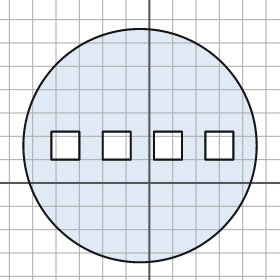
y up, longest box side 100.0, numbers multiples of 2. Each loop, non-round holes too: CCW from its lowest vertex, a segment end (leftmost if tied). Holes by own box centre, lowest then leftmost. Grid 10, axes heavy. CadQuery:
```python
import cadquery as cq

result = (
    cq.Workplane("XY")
    .moveTo(-4.0, 16.0)
    .circle(50.0)
    .moveTo(-42.0, 10.0)
    .lineTo(-30.0, 10.0)
    .lineTo(-30.0, 22.0)
    .lineTo(-42.0, 22.0)
    .close()
    .moveTo(-20.0, 10.0)
    .lineTo(-8.0, 10.0)
    .lineTo(-8.0, 22.0)
    .lineTo(-20.0, 22.0)
    .close()
    .moveTo(2.0, 10.0)
    .lineTo(14.0, 10.0)
    .lineTo(14.0, 22.0)
    .lineTo(2.0, 22.0)
    .close()
    .moveTo(24.0, 10.0)
    .lineTo(36.0, 10.0)
    .lineTo(36.0, 22.0)
    .lineTo(24.0, 22.0)
    .close()
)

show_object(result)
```